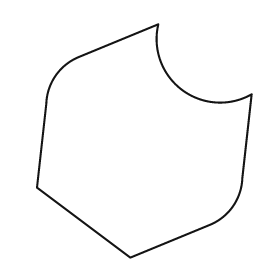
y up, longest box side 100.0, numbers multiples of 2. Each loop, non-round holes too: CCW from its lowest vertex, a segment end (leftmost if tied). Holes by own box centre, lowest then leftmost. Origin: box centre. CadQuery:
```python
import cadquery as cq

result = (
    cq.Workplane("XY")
    .moveTo(-6.0, -50.0)
    .lineTo(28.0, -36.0)
    .threePointArc((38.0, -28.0), (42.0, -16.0))
    .lineTo(46.0, 20.0)
    .threePointArc((16.0, 22.0), (6.0, 50.0))
    .lineTo(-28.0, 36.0)
    .threePointArc((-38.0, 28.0), (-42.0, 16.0))
    .lineTo(-46.0, -20.0)
    .close()
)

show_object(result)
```